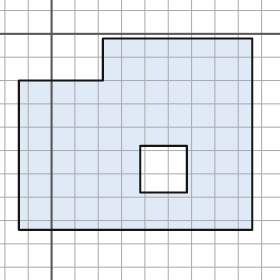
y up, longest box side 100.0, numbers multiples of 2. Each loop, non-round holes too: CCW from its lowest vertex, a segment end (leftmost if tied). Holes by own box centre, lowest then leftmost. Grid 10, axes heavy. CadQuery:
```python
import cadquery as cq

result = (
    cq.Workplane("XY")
    .moveTo(-14.0, -84.0)
    .lineTo(86.0, -84.0)
    .lineTo(86.0, -2.0)
    .lineTo(22.0, -2.0)
    .lineTo(22.0, -20.0)
    .lineTo(-14.0, -20.0)
    .close()
    .moveTo(38.0, -68.0)
    .lineTo(58.0, -68.0)
    .lineTo(58.0, -48.0)
    .lineTo(38.0, -48.0)
    .close()
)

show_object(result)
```